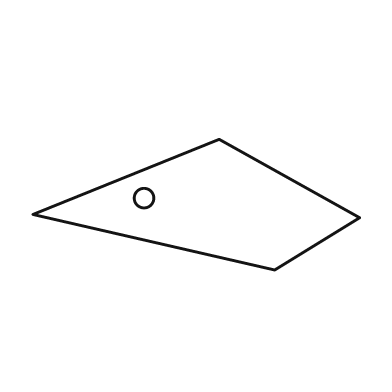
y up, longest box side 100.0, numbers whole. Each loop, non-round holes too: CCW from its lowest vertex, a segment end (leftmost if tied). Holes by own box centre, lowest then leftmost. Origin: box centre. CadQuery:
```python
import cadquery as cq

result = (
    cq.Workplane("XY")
    .moveTo(24.0, -20.0)
    .lineTo(50.0, -4.0)
    .lineTo(7.0, 20.0)
    .lineTo(-50.0, -3.0)
    .close()
    .moveTo(-16.0, 2.0)
    .circle(3.0)
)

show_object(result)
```